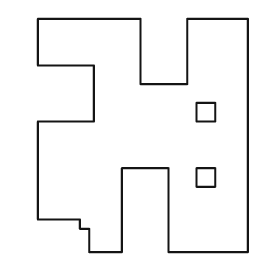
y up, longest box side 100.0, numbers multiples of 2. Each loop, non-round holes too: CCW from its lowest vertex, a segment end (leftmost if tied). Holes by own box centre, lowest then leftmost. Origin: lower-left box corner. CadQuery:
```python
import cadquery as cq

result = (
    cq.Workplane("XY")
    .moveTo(22.0, 0.0)
    .lineTo(36.0, 0.0)
    .lineTo(36.0, 36.0)
    .lineTo(56.0, 36.0)
    .lineTo(56.0, 0.0)
    .lineTo(90.0, 0.0)
    .lineTo(90.0, 100.0)
    .lineTo(64.0, 100.0)
    .lineTo(64.0, 72.0)
    .lineTo(44.0, 72.0)
    .lineTo(44.0, 100.0)
    .lineTo(0.0, 100.0)
    .lineTo(0.0, 80.0)
    .lineTo(24.0, 80.0)
    .lineTo(24.0, 56.0)
    .lineTo(0.0, 56.0)
    .lineTo(0.0, 14.0)
    .lineTo(18.0, 14.0)
    .lineTo(18.0, 10.0)
    .lineTo(22.0, 10.0)
    .close()
    .moveTo(68.0, 28.0)
    .lineTo(76.0, 28.0)
    .lineTo(76.0, 36.0)
    .lineTo(68.0, 36.0)
    .close()
    .moveTo(68.0, 56.0)
    .lineTo(76.0, 56.0)
    .lineTo(76.0, 64.0)
    .lineTo(68.0, 64.0)
    .close()
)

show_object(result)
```